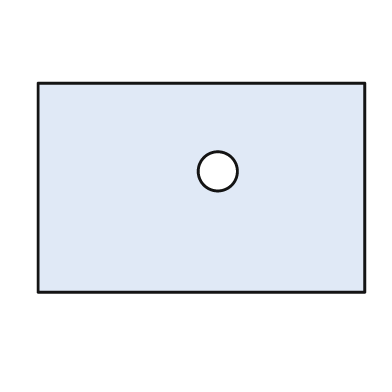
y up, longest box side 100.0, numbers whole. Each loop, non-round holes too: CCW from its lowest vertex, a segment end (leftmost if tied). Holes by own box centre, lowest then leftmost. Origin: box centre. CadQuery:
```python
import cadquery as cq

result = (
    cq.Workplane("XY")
    .moveTo(-50.0, -32.0)
    .lineTo(50.0, -32.0)
    .lineTo(50.0, 32.0)
    .lineTo(-50.0, 32.0)
    .close()
    .moveTo(5.0, 5.0)
    .circle(6.0)
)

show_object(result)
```